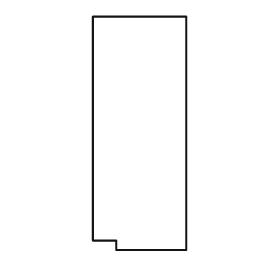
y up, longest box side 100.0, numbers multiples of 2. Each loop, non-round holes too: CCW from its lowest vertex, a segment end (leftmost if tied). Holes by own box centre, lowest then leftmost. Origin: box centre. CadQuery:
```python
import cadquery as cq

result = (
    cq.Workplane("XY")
    .moveTo(-10.0, -50.0)
    .lineTo(20.0, -50.0)
    .lineTo(20.0, 50.0)
    .lineTo(-20.0, 50.0)
    .lineTo(-20.0, -46.0)
    .lineTo(-10.0, -46.0)
    .close()
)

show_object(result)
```